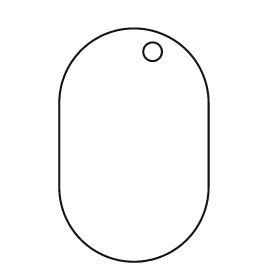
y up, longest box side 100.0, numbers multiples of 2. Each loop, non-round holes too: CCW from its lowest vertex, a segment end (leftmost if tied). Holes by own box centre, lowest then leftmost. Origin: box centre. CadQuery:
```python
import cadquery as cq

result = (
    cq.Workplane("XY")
    .moveTo(-32.0, -18.0)
    .threePointArc((0.0, -50.0), (32.0, -18.0))
    .lineTo(32.0, 18.0)
    .threePointArc((0.0, 50.0), (-32.0, 18.0))
    .close()
    .moveTo(8.0, 40.0)
    .circle(4.0)
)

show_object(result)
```